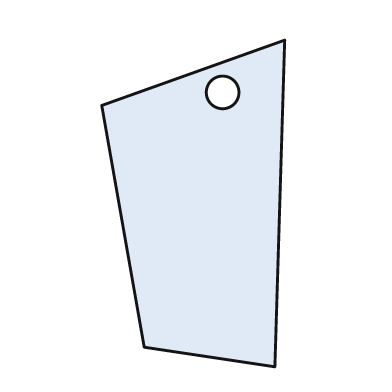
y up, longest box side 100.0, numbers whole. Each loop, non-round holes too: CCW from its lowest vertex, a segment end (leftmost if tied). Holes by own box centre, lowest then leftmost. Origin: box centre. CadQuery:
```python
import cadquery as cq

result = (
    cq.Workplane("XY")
    .moveTo(25.0, -50.0)
    .lineTo(28.0, 50.0)
    .lineTo(-28.0, 30.0)
    .lineTo(-15.0, -44.0)
    .close()
    .moveTo(9.0, 34.0)
    .circle(5.0)
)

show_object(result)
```